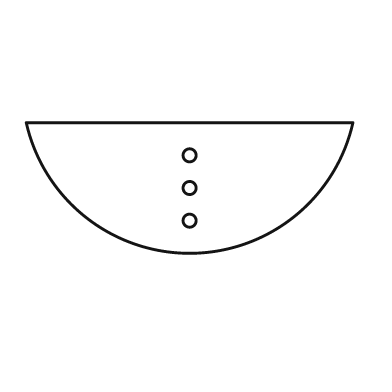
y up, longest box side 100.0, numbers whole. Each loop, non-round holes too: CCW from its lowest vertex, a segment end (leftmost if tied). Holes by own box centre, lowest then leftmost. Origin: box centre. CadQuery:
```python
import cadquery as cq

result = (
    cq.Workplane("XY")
    .moveTo(-50.0, 20.0)
    .threePointArc((0.0, -20.0), (50.0, 20.0))
    .close()
    .moveTo(0.0, -10.0)
    .circle(2.0)
    .moveTo(0.0, 0.0)
    .circle(2.0)
    .moveTo(0.0, 10.0)
    .circle(2.0)
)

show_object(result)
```